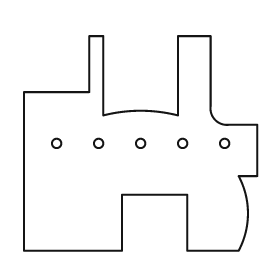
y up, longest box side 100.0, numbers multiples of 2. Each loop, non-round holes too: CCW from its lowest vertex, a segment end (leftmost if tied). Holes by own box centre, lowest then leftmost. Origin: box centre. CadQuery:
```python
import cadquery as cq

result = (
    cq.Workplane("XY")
    .moveTo(-50.0, -46.0)
    .lineTo(-8.0, -46.0)
    .lineTo(-8.0, -22.0)
    .lineTo(20.0, -22.0)
    .lineTo(20.0, -46.0)
    .lineTo(42.0, -46.0)
    .threePointArc((46.0, -30.0), (42.0, -14.0))
    .lineTo(50.0, -14.0)
    .lineTo(50.0, 8.0)
    .lineTo(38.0, 8.0)
    .threePointArc((32.0, 10.0), (30.0, 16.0))
    .lineTo(30.0, 46.0)
    .lineTo(16.0, 46.0)
    .lineTo(16.0, 12.0)
    .threePointArc((0.0, 14.0), (-16.0, 12.0))
    .lineTo(-16.0, 46.0)
    .lineTo(-22.0, 46.0)
    .lineTo(-22.0, 22.0)
    .lineTo(-50.0, 22.0)
    .close()
    .moveTo(-36.0, 0.0)
    .circle(2.0)
    .moveTo(-18.0, 0.0)
    .circle(2.0)
    .moveTo(0.0, 0.0)
    .circle(2.0)
    .moveTo(18.0, 0.0)
    .circle(2.0)
    .moveTo(36.0, 0.0)
    .circle(2.0)
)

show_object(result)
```